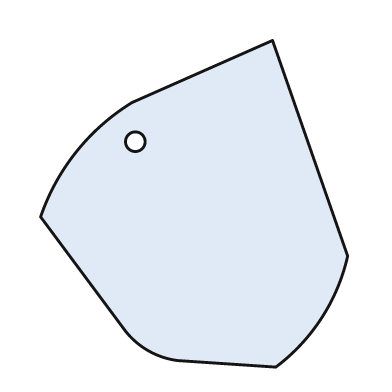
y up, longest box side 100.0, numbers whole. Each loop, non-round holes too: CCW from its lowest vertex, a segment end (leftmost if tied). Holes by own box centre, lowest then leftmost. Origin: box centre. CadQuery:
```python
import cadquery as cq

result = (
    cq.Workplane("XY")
    .moveTo(25.0, -50.0)
    .threePointArc((39.0, -35.0), (47.0, -16.0))
    .lineTo(24.0, 50.0)
    .lineTo(-19.0, 31.0)
    .threePointArc((-36.0, 16.0), (-47.0, -4.0))
    .lineTo(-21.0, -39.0)
    .threePointArc((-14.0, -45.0), (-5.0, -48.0))
    .close()
    .moveTo(-18.0, 19.0)
    .circle(3.0)
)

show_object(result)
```